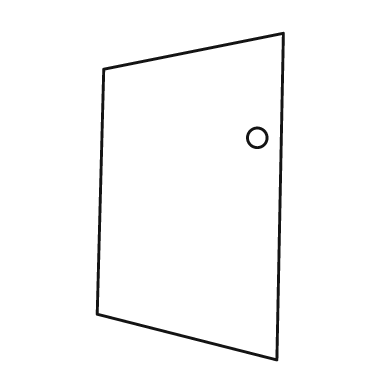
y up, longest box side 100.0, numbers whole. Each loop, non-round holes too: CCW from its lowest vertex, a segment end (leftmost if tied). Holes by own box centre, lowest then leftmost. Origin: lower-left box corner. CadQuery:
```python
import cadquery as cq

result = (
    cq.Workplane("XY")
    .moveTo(55.0, 0.0)
    .lineTo(57.0, 100.0)
    .lineTo(2.0, 89.0)
    .lineTo(0.0, 14.0)
    .close()
    .moveTo(49.0, 68.0)
    .circle(3.0)
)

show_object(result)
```